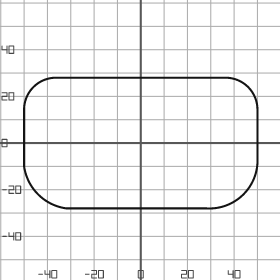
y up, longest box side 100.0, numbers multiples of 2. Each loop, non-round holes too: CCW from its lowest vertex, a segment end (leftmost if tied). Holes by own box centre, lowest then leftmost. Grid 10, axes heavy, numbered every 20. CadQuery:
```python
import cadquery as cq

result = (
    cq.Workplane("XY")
    .moveTo(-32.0, -28.0)
    .lineTo(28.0, -28.0)
    .threePointArc((44.0, -22.0), (50.0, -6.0))
    .lineTo(50.0, 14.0)
    .threePointArc((46.0, 24.0), (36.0, 28.0))
    .lineTo(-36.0, 28.0)
    .threePointArc((-46.0, 24.0), (-50.0, 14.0))
    .lineTo(-50.0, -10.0)
    .threePointArc((-44.0, -22.0), (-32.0, -28.0))
    .close()
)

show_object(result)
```